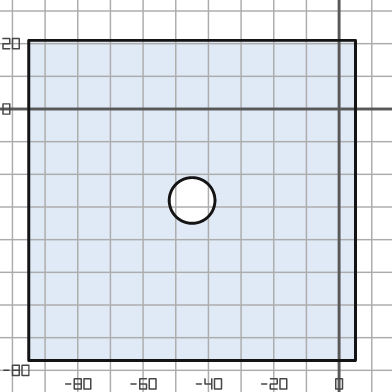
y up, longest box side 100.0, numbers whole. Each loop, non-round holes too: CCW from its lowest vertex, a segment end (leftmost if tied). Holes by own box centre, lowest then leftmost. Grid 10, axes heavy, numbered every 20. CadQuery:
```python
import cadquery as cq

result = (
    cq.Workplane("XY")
    .moveTo(-95.0, -77.0)
    .lineTo(5.0, -77.0)
    .lineTo(5.0, 21.0)
    .lineTo(-95.0, 21.0)
    .close()
    .moveTo(-45.0, -28.0)
    .circle(7.0)
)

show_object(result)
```